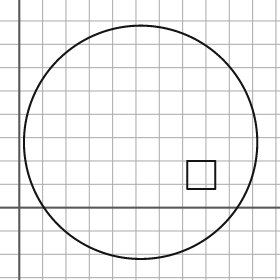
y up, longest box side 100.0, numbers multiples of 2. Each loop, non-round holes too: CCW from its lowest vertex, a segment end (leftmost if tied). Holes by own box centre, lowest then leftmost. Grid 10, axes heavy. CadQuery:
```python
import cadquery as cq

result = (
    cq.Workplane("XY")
    .moveTo(52.0, 28.0)
    .circle(50.0)
    .moveTo(72.0, 8.0)
    .lineTo(84.0, 8.0)
    .lineTo(84.0, 20.0)
    .lineTo(72.0, 20.0)
    .close()
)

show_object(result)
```